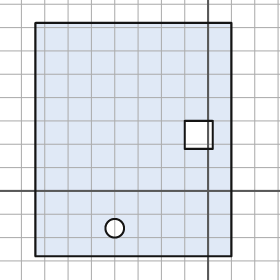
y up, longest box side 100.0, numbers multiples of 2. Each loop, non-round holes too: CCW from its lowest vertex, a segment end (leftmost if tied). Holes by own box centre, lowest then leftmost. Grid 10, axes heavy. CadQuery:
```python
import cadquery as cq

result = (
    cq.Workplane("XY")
    .moveTo(-74.0, -28.0)
    .lineTo(10.0, -28.0)
    .lineTo(10.0, 72.0)
    .lineTo(-74.0, 72.0)
    .close()
    .moveTo(-40.0, -16.0)
    .circle(4.0)
    .moveTo(-10.0, 18.0)
    .lineTo(2.0, 18.0)
    .lineTo(2.0, 30.0)
    .lineTo(-10.0, 30.0)
    .close()
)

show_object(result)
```